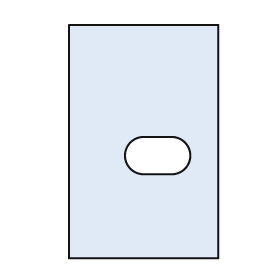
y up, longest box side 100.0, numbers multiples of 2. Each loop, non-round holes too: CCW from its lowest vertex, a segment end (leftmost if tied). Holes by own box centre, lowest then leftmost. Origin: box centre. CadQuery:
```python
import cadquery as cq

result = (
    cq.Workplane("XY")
    .moveTo(-32.0, -50.0)
    .lineTo(32.0, -50.0)
    .lineTo(32.0, 50.0)
    .lineTo(-32.0, 50.0)
    .close()
    .moveTo(0.0, -14.0)
    .lineTo(12.0, -14.0)
    .threePointArc((20.0, -6.0), (12.0, 2.0))
    .lineTo(0.0, 2.0)
    .threePointArc((-8.0, -6.0), (0.0, -14.0))
    .close()
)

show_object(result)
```